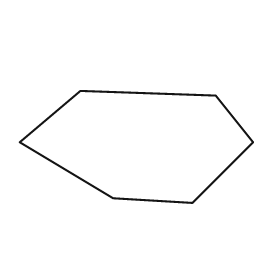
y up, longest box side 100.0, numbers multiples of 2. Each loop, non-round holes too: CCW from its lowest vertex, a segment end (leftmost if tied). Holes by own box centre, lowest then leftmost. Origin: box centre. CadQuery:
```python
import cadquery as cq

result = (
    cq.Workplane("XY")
    .moveTo(24.0, -24.0)
    .lineTo(50.0, 2.0)
    .lineTo(34.0, 22.0)
    .lineTo(-24.0, 24.0)
    .lineTo(-50.0, 2.0)
    .lineTo(-10.0, -22.0)
    .close()
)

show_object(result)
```